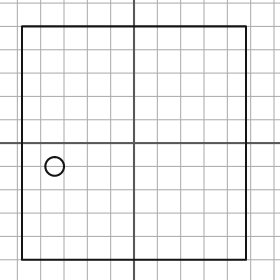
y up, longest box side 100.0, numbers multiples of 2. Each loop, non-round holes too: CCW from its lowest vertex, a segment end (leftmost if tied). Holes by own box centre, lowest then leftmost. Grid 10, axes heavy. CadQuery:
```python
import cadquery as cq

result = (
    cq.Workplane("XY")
    .moveTo(-48.0, -50.0)
    .lineTo(48.0, -50.0)
    .lineTo(48.0, 50.0)
    .lineTo(-48.0, 50.0)
    .close()
    .moveTo(-34.0, -10.0)
    .circle(4.0)
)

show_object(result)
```